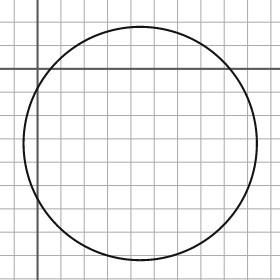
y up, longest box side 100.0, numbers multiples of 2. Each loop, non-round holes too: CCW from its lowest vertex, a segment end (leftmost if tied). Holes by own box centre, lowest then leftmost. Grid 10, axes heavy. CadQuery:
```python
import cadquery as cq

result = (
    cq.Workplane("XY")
    .moveTo(44.0, -32.0)
    .circle(50.0)
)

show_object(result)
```